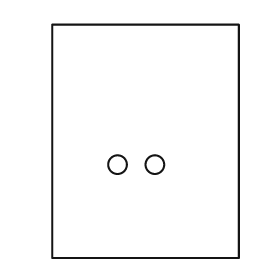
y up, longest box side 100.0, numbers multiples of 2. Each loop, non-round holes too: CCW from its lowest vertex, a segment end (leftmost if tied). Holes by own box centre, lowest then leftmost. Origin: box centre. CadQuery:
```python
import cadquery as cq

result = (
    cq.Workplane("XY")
    .moveTo(-40.0, -50.0)
    .lineTo(40.0, -50.0)
    .lineTo(40.0, 50.0)
    .lineTo(-40.0, 50.0)
    .close()
    .moveTo(-12.0, -10.0)
    .circle(4.0)
    .moveTo(4.0, -10.0)
    .circle(4.0)
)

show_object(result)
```